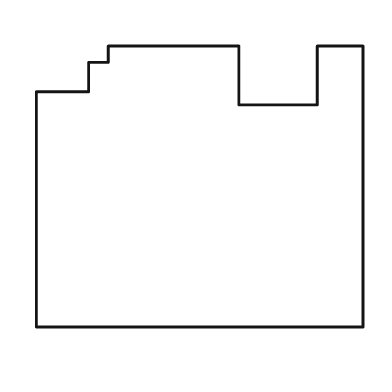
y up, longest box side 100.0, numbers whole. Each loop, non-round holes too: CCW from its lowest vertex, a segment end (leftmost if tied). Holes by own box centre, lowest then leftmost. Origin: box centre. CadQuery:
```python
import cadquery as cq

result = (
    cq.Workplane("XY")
    .moveTo(-50.0, -43.0)
    .lineTo(50.0, -43.0)
    .lineTo(50.0, 43.0)
    .lineTo(36.0, 43.0)
    .lineTo(36.0, 25.0)
    .lineTo(12.0, 25.0)
    .lineTo(12.0, 43.0)
    .lineTo(-28.0, 43.0)
    .lineTo(-28.0, 38.0)
    .lineTo(-34.0, 38.0)
    .lineTo(-34.0, 29.0)
    .lineTo(-50.0, 29.0)
    .close()
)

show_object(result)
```